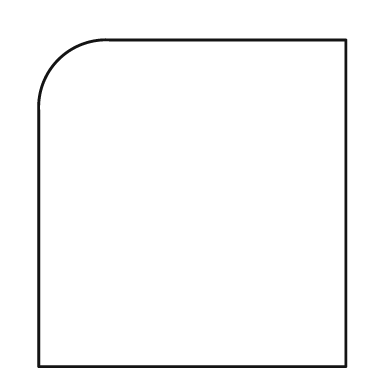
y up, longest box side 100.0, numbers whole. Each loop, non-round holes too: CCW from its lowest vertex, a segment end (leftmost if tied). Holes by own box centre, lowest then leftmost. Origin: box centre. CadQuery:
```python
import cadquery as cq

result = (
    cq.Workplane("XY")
    .moveTo(-47.0, -50.0)
    .lineTo(47.0, -50.0)
    .lineTo(47.0, 50.0)
    .lineTo(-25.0, 50.0)
    .threePointArc((-41.0, 44.0), (-47.0, 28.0))
    .close()
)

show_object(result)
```